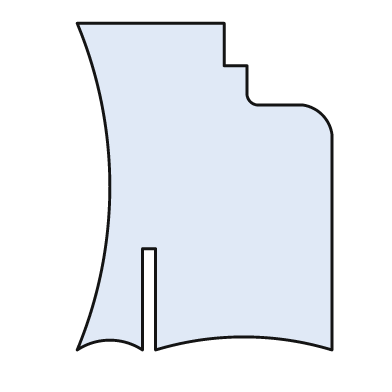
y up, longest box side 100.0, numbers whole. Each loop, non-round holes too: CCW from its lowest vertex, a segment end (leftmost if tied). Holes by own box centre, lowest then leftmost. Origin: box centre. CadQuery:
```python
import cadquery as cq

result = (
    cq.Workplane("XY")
    .moveTo(-39.0, -50.0)
    .threePointArc((-29.0, -47.0), (-19.0, -50.0))
    .lineTo(-19.0, -19.0)
    .lineTo(-15.0, -19.0)
    .lineTo(-15.0, -50.0)
    .threePointArc((12.0, -46.0), (39.0, -50.0))
    .lineTo(39.0, 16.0)
    .threePointArc((36.0, 22.0), (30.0, 25.0))
    .lineTo(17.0, 25.0)
    .threePointArc((14.0, 26.0), (13.0, 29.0))
    .lineTo(13.0, 37.0)
    .lineTo(6.0, 37.0)
    .lineTo(6.0, 50.0)
    .lineTo(-39.0, 50.0)
    .threePointArc((-29.0, 0.0), (-39.0, -50.0))
    .close()
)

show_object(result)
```